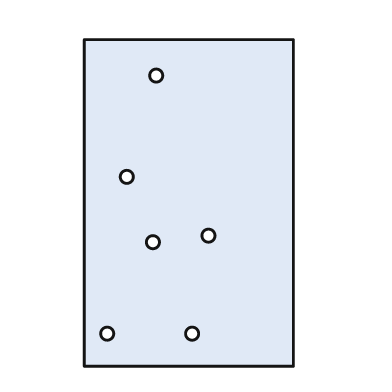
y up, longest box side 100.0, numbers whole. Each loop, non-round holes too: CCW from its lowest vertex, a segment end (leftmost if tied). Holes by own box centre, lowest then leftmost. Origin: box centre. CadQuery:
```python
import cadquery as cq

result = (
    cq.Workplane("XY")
    .moveTo(-32.0, -50.0)
    .lineTo(32.0, -50.0)
    .lineTo(32.0, 50.0)
    .lineTo(-32.0, 50.0)
    .close()
    .moveTo(-25.0, -40.0)
    .circle(2.0)
    .moveTo(1.0, -40.0)
    .circle(2.0)
    .moveTo(-11.0, -12.0)
    .circle(2.0)
    .moveTo(6.0, -10.0)
    .circle(2.0)
    .moveTo(-19.0, 8.0)
    .circle(2.0)
    .moveTo(-10.0, 39.0)
    .circle(2.0)
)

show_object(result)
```